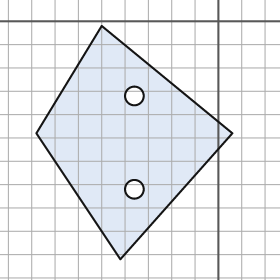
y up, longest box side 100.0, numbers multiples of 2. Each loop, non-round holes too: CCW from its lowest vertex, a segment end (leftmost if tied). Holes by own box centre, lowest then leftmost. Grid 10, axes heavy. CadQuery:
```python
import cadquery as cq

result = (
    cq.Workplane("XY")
    .moveTo(-42.0, -102.0)
    .lineTo(6.0, -48.0)
    .lineTo(-50.0, -2.0)
    .lineTo(-78.0, -48.0)
    .close()
    .moveTo(-36.0, -72.0)
    .circle(4.0)
    .moveTo(-36.0, -32.0)
    .circle(4.0)
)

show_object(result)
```